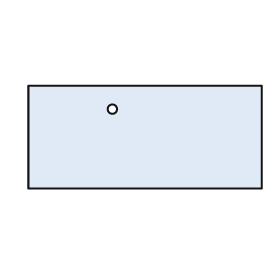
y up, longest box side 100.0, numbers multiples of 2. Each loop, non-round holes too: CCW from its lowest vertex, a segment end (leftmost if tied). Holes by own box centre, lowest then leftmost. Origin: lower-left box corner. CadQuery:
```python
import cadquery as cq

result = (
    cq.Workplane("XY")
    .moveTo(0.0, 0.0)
    .lineTo(100.0, 0.0)
    .lineTo(100.0, 44.0)
    .lineTo(0.0, 44.0)
    .close()
    .moveTo(36.0, 34.0)
    .circle(2.0)
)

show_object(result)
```